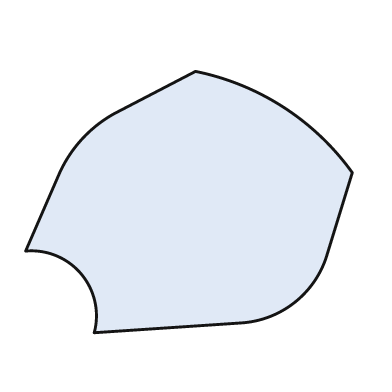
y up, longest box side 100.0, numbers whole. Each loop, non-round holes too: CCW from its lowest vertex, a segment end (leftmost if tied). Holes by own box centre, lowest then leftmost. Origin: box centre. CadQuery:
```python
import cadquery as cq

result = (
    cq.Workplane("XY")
    .moveTo(-29.0, -40.0)
    .lineTo(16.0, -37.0)
    .threePointArc((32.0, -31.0), (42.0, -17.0))
    .lineTo(50.0, 9.0)
    .threePointArc((29.0, 29.0), (2.0, 40.0))
    .lineTo(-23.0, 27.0)
    .threePointArc((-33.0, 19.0), (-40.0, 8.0))
    .lineTo(-50.0, -15.0)
    .threePointArc((-33.0, -22.0), (-29.0, -40.0))
    .close()
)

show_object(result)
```